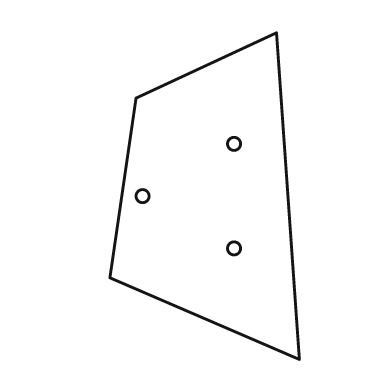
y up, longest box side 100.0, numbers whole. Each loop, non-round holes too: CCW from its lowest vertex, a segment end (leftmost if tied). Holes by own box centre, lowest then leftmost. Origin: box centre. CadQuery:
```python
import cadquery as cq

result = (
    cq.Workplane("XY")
    .moveTo(29.0, -50.0)
    .lineTo(22.0, 50.0)
    .lineTo(-21.0, 30.0)
    .lineTo(-29.0, -25.0)
    .close()
    .moveTo(9.0, -16.0)
    .circle(2.0)
    .moveTo(-19.0, 0.0)
    .circle(2.0)
    .moveTo(9.0, 16.0)
    .circle(2.0)
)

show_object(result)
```